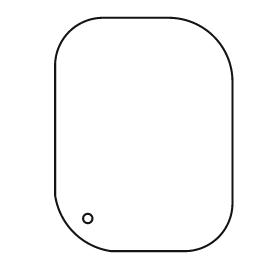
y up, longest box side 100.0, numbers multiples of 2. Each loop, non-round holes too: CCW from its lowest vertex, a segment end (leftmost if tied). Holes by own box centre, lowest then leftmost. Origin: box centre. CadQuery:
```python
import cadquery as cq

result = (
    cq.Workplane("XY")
    .moveTo(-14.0, -50.0)
    .lineTo(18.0, -50.0)
    .threePointArc((32.0, -44.0), (38.0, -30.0))
    .lineTo(38.0, 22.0)
    .threePointArc((30.0, 42.0), (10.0, 50.0))
    .lineTo(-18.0, 50.0)
    .threePointArc((-32.0, 44.0), (-38.0, 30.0))
    .lineTo(-38.0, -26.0)
    .threePointArc((-30.0, -42.0), (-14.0, -50.0))
    .close()
    .moveTo(-24.0, -36.0)
    .circle(2.0)
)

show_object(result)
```